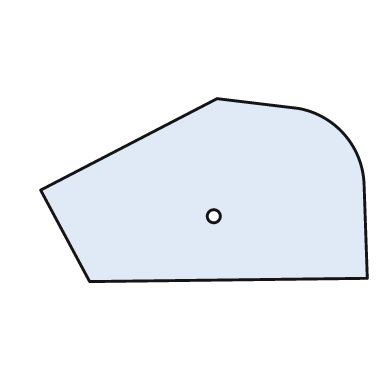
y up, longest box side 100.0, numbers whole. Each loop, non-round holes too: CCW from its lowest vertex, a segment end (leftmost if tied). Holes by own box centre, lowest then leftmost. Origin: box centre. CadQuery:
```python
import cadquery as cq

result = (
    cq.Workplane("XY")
    .moveTo(-35.0, -28.0)
    .lineTo(50.0, -27.0)
    .lineTo(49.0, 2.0)
    .threePointArc((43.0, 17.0), (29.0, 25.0))
    .lineTo(4.0, 28.0)
    .lineTo(-50.0, 0.0)
    .close()
    .moveTo(3.0, -8.0)
    .circle(2.0)
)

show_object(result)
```